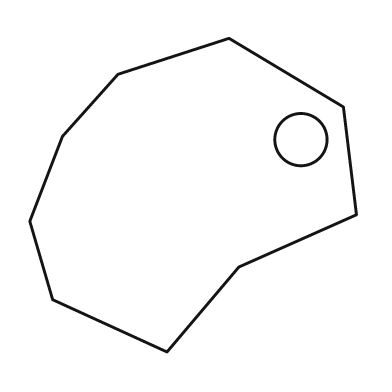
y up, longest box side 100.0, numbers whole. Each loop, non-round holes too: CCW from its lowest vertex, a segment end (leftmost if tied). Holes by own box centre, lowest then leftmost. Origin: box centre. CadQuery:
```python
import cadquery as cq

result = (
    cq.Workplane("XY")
    .moveTo(-8.0, -48.0)
    .lineTo(14.0, -22.0)
    .lineTo(50.0, -6.0)
    .lineTo(46.0, 27.0)
    .lineTo(11.0, 48.0)
    .lineTo(-23.0, 37.0)
    .lineTo(-40.0, 18.0)
    .lineTo(-50.0, -8.0)
    .lineTo(-43.0, -32.0)
    .close()
    .moveTo(33.0, 17.0)
    .circle(8.0)
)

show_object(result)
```